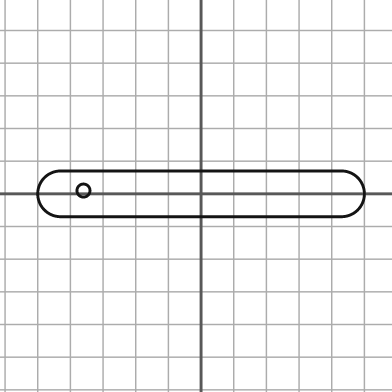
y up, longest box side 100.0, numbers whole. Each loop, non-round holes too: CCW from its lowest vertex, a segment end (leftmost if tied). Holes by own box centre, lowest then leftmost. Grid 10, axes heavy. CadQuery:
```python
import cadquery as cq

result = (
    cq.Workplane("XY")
    .moveTo(-43.0, -7.0)
    .lineTo(43.0, -7.0)
    .threePointArc((50.0, 0.0), (43.0, 7.0))
    .lineTo(-43.0, 7.0)
    .threePointArc((-50.0, 0.0), (-43.0, -7.0))
    .close()
    .moveTo(-36.0, 1.0)
    .circle(2.0)
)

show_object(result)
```